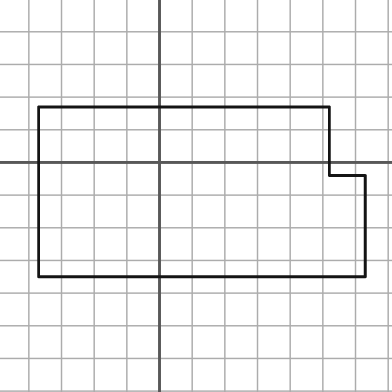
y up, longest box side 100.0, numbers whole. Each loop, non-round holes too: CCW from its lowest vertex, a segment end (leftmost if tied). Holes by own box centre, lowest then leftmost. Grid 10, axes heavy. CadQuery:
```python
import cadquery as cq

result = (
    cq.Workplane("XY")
    .moveTo(-37.0, -35.0)
    .lineTo(63.0, -35.0)
    .lineTo(63.0, -4.0)
    .lineTo(52.0, -4.0)
    .lineTo(52.0, 17.0)
    .lineTo(-37.0, 17.0)
    .close()
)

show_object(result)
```